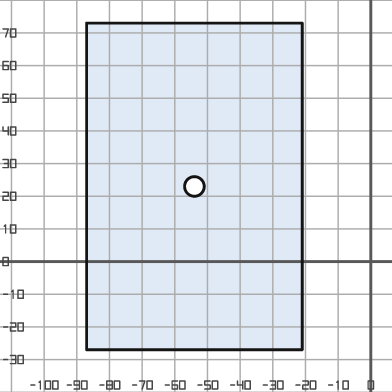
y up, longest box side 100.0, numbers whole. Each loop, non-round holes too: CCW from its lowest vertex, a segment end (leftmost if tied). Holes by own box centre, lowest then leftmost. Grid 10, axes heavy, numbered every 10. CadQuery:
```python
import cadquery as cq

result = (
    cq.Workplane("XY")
    .moveTo(-87.0, -27.0)
    .lineTo(-21.0, -27.0)
    .lineTo(-21.0, 73.0)
    .lineTo(-87.0, 73.0)
    .close()
    .moveTo(-54.0, 23.0)
    .circle(3.0)
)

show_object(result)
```